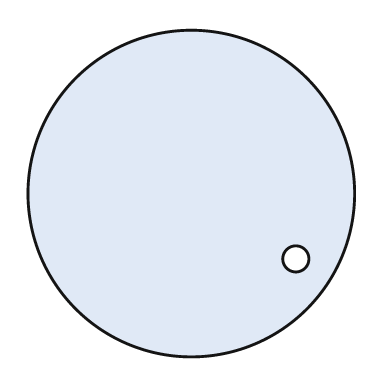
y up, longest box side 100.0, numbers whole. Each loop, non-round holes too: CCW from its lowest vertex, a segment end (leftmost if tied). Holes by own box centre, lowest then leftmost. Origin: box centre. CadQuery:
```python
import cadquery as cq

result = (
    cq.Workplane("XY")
    .moveTo(0.0, 0.0)
    .circle(50.0)
    .moveTo(32.0, -20.0)
    .circle(4.0)
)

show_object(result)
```